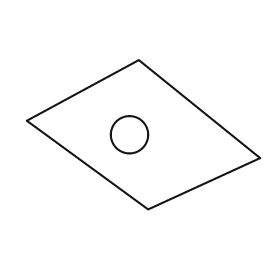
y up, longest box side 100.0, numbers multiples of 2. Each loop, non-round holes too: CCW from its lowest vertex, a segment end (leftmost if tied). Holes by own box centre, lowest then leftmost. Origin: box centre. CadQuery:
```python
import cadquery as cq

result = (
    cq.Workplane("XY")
    .moveTo(2.0, -32.0)
    .lineTo(50.0, -10.0)
    .lineTo(-2.0, 32.0)
    .lineTo(-50.0, 6.0)
    .close()
    .moveTo(-6.0, 0.0)
    .circle(8.0)
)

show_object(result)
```